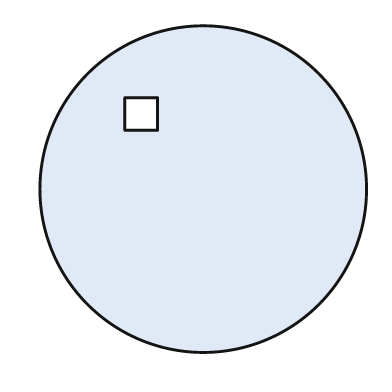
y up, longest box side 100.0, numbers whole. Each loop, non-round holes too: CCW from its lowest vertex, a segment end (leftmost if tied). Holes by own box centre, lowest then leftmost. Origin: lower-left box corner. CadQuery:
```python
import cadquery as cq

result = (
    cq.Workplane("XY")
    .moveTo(50.0, 50.0)
    .circle(50.0)
    .moveTo(26.0, 68.0)
    .lineTo(36.0, 68.0)
    .lineTo(36.0, 78.0)
    .lineTo(26.0, 78.0)
    .close()
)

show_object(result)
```